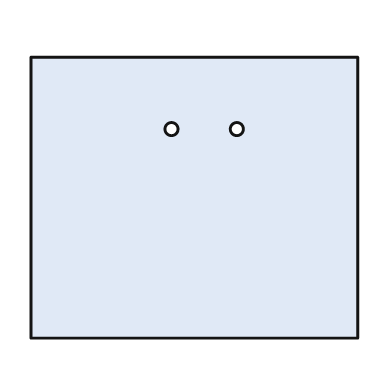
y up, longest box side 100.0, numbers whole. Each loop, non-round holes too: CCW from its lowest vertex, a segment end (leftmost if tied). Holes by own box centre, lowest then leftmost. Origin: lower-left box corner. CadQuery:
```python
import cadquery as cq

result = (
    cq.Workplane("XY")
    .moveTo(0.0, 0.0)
    .lineTo(100.0, 0.0)
    .lineTo(100.0, 86.0)
    .lineTo(0.0, 86.0)
    .close()
    .moveTo(43.0, 64.0)
    .circle(2.0)
    .moveTo(63.0, 64.0)
    .circle(2.0)
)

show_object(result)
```